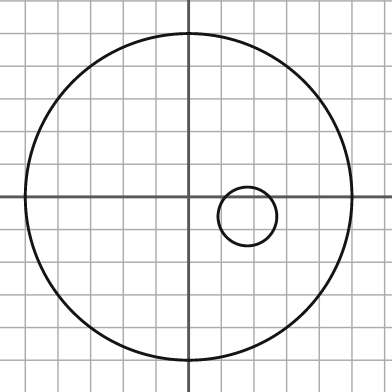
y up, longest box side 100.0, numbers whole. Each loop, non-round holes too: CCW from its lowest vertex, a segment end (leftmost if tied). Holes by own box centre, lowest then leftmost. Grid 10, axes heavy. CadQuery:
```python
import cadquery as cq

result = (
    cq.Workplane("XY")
    .moveTo(0.0, 0.0)
    .circle(50.0)
    .moveTo(18.0, -6.0)
    .circle(9.0)
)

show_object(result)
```